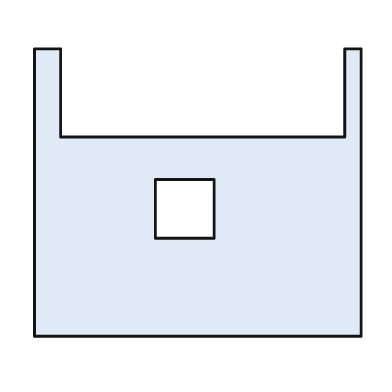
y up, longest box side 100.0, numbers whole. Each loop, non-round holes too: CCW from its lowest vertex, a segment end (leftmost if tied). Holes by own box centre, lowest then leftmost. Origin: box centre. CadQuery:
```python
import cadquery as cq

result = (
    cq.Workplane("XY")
    .moveTo(-50.0, -44.0)
    .lineTo(50.0, -44.0)
    .lineTo(50.0, 44.0)
    .lineTo(45.0, 44.0)
    .lineTo(45.0, 17.0)
    .lineTo(-42.0, 17.0)
    .lineTo(-42.0, 44.0)
    .lineTo(-50.0, 44.0)
    .close()
    .moveTo(-13.0, -14.0)
    .lineTo(5.0, -14.0)
    .lineTo(5.0, 4.0)
    .lineTo(-13.0, 4.0)
    .close()
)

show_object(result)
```